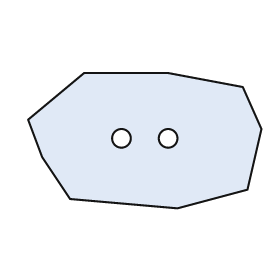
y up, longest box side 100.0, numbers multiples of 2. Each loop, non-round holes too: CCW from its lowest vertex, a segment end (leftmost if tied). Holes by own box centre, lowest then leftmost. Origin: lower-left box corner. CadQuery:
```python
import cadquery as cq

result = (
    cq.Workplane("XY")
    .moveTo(64.0, 0.0)
    .lineTo(94.0, 8.0)
    .lineTo(100.0, 34.0)
    .lineTo(92.0, 52.0)
    .lineTo(60.0, 58.0)
    .lineTo(24.0, 58.0)
    .lineTo(0.0, 38.0)
    .lineTo(6.0, 22.0)
    .lineTo(18.0, 4.0)
    .close()
    .moveTo(40.0, 30.0)
    .circle(4.0)
    .moveTo(60.0, 30.0)
    .circle(4.0)
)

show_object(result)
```